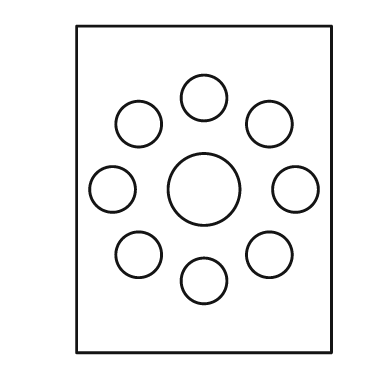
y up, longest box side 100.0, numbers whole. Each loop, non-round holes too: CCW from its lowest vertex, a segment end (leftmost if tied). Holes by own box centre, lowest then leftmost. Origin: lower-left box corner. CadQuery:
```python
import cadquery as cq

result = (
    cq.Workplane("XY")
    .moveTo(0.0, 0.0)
    .lineTo(78.0, 0.0)
    .lineTo(78.0, 100.0)
    .lineTo(0.0, 100.0)
    .close()
    .moveTo(39.0, 22.0)
    .circle(7.0)
    .moveTo(19.0, 30.0)
    .circle(7.0)
    .moveTo(59.0, 30.0)
    .circle(7.0)
    .moveTo(11.0, 50.0)
    .circle(7.0)
    .moveTo(39.0, 50.0)
    .circle(11.0)
    .moveTo(67.0, 50.0)
    .circle(7.0)
    .moveTo(19.0, 70.0)
    .circle(7.0)
    .moveTo(59.0, 70.0)
    .circle(7.0)
    .moveTo(39.0, 78.0)
    .circle(7.0)
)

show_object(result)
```